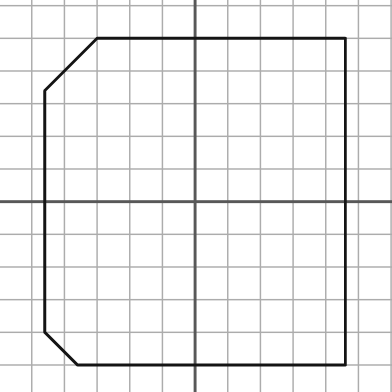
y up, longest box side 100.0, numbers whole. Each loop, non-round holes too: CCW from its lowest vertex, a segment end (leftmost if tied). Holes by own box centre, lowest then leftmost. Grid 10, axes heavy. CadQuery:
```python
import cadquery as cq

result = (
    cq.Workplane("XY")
    .moveTo(-36.0, -50.0)
    .lineTo(46.0, -50.0)
    .lineTo(46.0, 50.0)
    .lineTo(-30.0, 50.0)
    .lineTo(-46.0, 34.0)
    .lineTo(-46.0, -40.0)
    .close()
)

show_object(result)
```